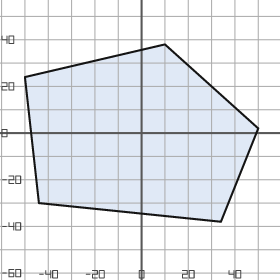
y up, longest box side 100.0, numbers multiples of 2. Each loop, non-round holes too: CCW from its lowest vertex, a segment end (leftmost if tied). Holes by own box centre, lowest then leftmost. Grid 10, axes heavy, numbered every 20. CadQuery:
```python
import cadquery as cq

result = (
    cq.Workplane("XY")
    .moveTo(34.0, -38.0)
    .lineTo(50.0, 2.0)
    .lineTo(10.0, 38.0)
    .lineTo(-50.0, 24.0)
    .lineTo(-44.0, -30.0)
    .close()
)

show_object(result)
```